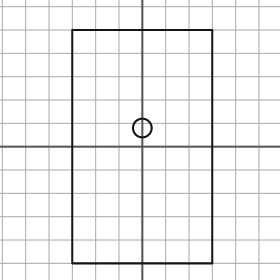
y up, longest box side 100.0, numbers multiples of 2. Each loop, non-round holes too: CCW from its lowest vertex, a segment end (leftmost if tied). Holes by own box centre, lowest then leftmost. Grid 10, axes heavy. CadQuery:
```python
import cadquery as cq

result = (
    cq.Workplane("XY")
    .moveTo(-30.0, -50.0)
    .lineTo(30.0, -50.0)
    .lineTo(30.0, 50.0)
    .lineTo(-30.0, 50.0)
    .close()
    .moveTo(0.0, 8.0)
    .circle(4.0)
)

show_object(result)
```